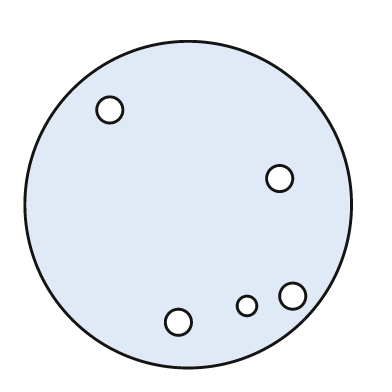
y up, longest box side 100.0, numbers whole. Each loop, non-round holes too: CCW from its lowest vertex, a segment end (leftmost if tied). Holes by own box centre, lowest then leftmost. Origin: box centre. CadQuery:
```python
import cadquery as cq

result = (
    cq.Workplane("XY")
    .moveTo(0.0, 0.0)
    .circle(50.0)
    .moveTo(-3.0, -36.0)
    .circle(4.0)
    .moveTo(18.0, -31.0)
    .circle(3.0)
    .moveTo(32.0, -28.0)
    .circle(4.0)
    .moveTo(28.0, 8.0)
    .circle(4.0)
    .moveTo(-24.0, 29.0)
    .circle(4.0)
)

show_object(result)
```